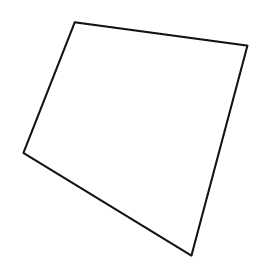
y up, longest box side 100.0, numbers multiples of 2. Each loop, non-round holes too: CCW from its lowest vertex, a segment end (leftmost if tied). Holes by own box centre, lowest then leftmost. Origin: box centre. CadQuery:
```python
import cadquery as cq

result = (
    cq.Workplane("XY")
    .moveTo(24.0, -50.0)
    .lineTo(48.0, 40.0)
    .lineTo(-26.0, 50.0)
    .lineTo(-48.0, -6.0)
    .close()
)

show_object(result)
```